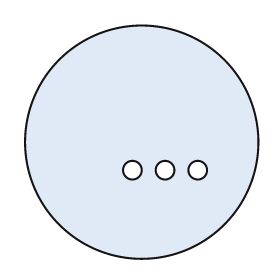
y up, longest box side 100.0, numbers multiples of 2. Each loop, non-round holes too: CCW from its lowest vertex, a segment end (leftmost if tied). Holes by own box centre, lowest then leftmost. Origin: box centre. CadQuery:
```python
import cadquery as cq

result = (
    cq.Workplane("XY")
    .moveTo(0.0, 0.0)
    .circle(50.0)
    .moveTo(-4.0, -12.0)
    .circle(4.0)
    .moveTo(10.0, -12.0)
    .circle(4.0)
    .moveTo(24.0, -12.0)
    .circle(4.0)
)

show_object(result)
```